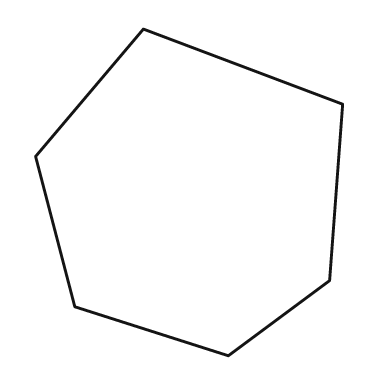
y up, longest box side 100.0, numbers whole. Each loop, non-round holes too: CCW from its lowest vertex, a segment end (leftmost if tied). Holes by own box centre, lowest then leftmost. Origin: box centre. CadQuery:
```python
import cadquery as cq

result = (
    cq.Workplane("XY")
    .moveTo(12.0, -50.0)
    .lineTo(43.0, -27.0)
    .lineTo(47.0, 27.0)
    .lineTo(-14.0, 50.0)
    .lineTo(-47.0, 11.0)
    .lineTo(-35.0, -35.0)
    .close()
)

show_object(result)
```